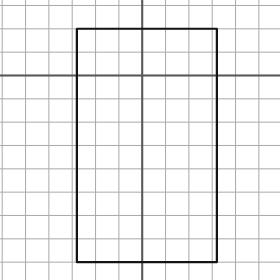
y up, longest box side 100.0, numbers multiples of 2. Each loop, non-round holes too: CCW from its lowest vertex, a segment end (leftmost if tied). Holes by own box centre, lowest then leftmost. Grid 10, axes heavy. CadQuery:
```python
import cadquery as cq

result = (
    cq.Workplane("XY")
    .moveTo(-28.0, -80.0)
    .lineTo(32.0, -80.0)
    .lineTo(32.0, 20.0)
    .lineTo(-28.0, 20.0)
    .close()
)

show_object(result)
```